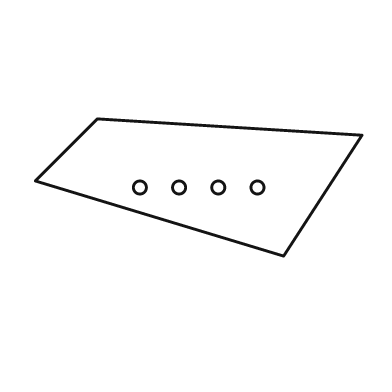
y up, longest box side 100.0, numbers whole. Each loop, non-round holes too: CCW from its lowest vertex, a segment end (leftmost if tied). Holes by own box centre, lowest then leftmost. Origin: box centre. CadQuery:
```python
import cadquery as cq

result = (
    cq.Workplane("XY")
    .moveTo(26.0, -21.0)
    .lineTo(50.0, 16.0)
    .lineTo(-31.0, 21.0)
    .lineTo(-50.0, 2.0)
    .close()
    .moveTo(-18.0, 0.0)
    .circle(2.0)
    .moveTo(-6.0, 0.0)
    .circle(2.0)
    .moveTo(6.0, 0.0)
    .circle(2.0)
    .moveTo(18.0, 0.0)
    .circle(2.0)
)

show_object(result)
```